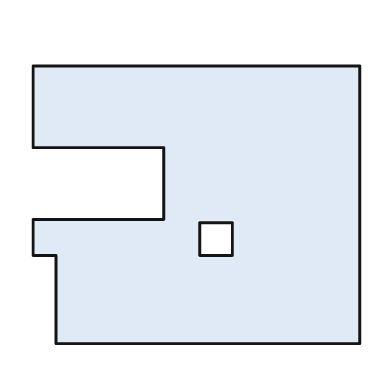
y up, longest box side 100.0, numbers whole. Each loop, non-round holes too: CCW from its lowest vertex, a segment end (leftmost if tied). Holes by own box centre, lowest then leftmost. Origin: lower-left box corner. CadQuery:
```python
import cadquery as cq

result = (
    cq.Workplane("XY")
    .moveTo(7.0, 0.0)
    .lineTo(100.0, 0.0)
    .lineTo(100.0, 85.0)
    .lineTo(0.0, 85.0)
    .lineTo(0.0, 60.0)
    .lineTo(40.0, 60.0)
    .lineTo(40.0, 38.0)
    .lineTo(0.0, 38.0)
    .lineTo(0.0, 27.0)
    .lineTo(7.0, 27.0)
    .close()
    .moveTo(51.0, 27.0)
    .lineTo(61.0, 27.0)
    .lineTo(61.0, 37.0)
    .lineTo(51.0, 37.0)
    .close()
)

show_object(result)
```